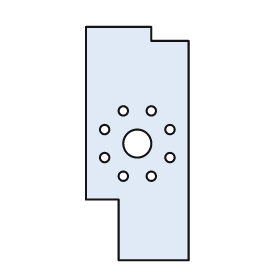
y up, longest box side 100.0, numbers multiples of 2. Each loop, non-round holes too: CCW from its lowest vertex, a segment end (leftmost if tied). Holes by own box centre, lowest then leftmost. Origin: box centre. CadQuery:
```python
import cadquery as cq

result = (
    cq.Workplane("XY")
    .moveTo(-8.0, -50.0)
    .lineTo(22.0, -50.0)
    .lineTo(22.0, 44.0)
    .lineTo(6.0, 44.0)
    .lineTo(6.0, 50.0)
    .lineTo(-22.0, 50.0)
    .lineTo(-22.0, -24.0)
    .lineTo(-8.0, -24.0)
    .close()
    .moveTo(-6.0, -14.0)
    .circle(2.0)
    .moveTo(6.0, -14.0)
    .circle(2.0)
    .moveTo(-14.0, -6.0)
    .circle(2.0)
    .moveTo(14.0, -6.0)
    .circle(2.0)
    .moveTo(0.0, 0.0)
    .circle(6.0)
    .moveTo(-14.0, 6.0)
    .circle(2.0)
    .moveTo(14.0, 6.0)
    .circle(2.0)
    .moveTo(-6.0, 14.0)
    .circle(2.0)
    .moveTo(6.0, 14.0)
    .circle(2.0)
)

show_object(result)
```